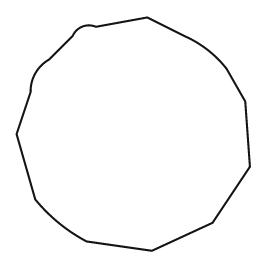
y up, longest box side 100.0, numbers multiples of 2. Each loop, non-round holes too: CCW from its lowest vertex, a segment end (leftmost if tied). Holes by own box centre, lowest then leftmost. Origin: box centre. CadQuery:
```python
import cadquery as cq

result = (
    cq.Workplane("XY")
    .moveTo(8.0, -50.0)
    .lineTo(34.0, -38.0)
    .lineTo(50.0, -14.0)
    .lineTo(48.0, 14.0)
    .lineTo(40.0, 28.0)
    .threePointArc((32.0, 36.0), (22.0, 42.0))
    .lineTo(6.0, 50.0)
    .lineTo(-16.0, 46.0)
    .threePointArc((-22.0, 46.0), (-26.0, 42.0))
    .lineTo(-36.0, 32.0)
    .threePointArc((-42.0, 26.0), (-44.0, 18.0))
    .lineTo(-50.0, 0.0)
    .lineTo(-42.0, -28.0)
    .threePointArc((-32.0, -38.0), (-20.0, -46.0))
    .close()
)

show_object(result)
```